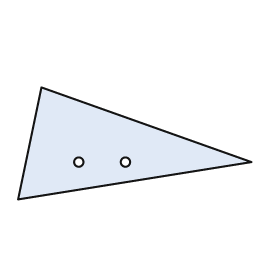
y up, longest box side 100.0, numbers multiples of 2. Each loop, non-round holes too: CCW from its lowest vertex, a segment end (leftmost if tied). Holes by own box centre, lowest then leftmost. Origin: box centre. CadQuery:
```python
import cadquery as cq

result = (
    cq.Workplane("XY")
    .moveTo(-50.0, -24.0)
    .lineTo(50.0, -8.0)
    .lineTo(-40.0, 24.0)
    .close()
    .moveTo(-24.0, -8.0)
    .circle(2.0)
    .moveTo(-4.0, -8.0)
    .circle(2.0)
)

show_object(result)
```